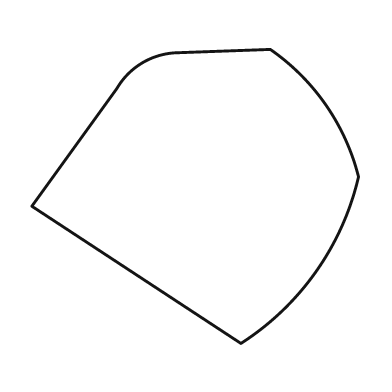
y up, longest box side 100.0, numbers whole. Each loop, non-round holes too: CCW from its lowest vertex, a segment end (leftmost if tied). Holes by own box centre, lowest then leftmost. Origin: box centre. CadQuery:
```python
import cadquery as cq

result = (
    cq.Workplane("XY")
    .moveTo(14.0, -45.0)
    .threePointArc((37.0, -23.0), (50.0, 6.0))
    .threePointArc((40.0, 28.0), (23.0, 45.0))
    .lineTo(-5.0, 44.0)
    .threePointArc((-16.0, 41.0), (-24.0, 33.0))
    .lineTo(-50.0, -3.0)
    .close()
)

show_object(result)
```